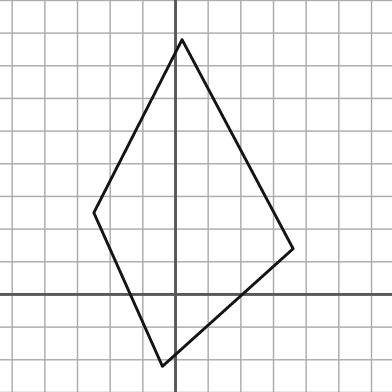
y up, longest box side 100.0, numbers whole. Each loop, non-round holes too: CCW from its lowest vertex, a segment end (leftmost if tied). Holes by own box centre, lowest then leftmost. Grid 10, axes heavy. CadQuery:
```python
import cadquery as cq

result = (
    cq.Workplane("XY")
    .moveTo(-4.0, -22.0)
    .lineTo(36.0, 14.0)
    .lineTo(2.0, 78.0)
    .lineTo(-25.0, 25.0)
    .close()
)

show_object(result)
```